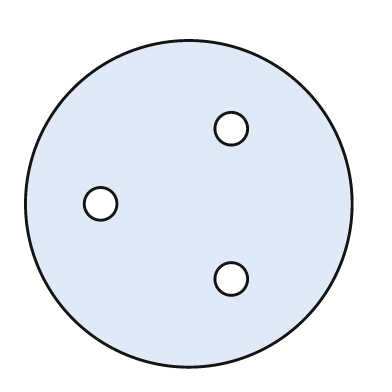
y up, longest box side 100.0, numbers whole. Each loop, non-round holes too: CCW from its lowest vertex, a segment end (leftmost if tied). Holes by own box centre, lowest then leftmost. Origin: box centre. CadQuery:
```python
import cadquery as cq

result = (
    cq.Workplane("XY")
    .moveTo(0.0, 0.0)
    .circle(50.0)
    .moveTo(13.0, -23.0)
    .circle(5.0)
    .moveTo(-27.0, 0.0)
    .circle(5.0)
    .moveTo(13.0, 23.0)
    .circle(5.0)
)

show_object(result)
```